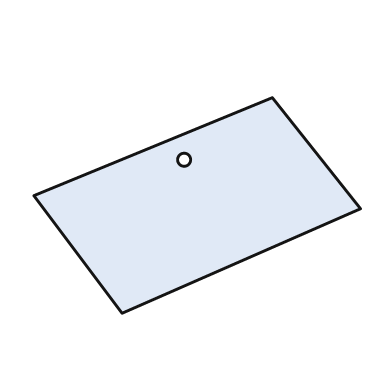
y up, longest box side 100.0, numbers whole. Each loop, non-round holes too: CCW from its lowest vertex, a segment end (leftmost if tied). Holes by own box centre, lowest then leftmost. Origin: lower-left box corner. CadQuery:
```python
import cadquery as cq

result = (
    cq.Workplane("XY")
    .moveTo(27.0, 0.0)
    .lineTo(100.0, 32.0)
    .lineTo(73.0, 66.0)
    .lineTo(0.0, 36.0)
    .close()
    .moveTo(46.0, 47.0)
    .circle(2.0)
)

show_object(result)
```